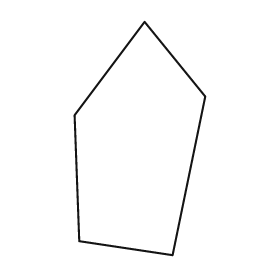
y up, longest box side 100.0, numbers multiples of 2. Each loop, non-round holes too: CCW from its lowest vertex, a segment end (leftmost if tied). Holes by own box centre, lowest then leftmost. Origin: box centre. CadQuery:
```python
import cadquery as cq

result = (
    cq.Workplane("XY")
    .moveTo(14.0, -50.0)
    .lineTo(28.0, 18.0)
    .lineTo(2.0, 50.0)
    .lineTo(-28.0, 10.0)
    .lineTo(-26.0, -44.0)
    .close()
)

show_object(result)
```